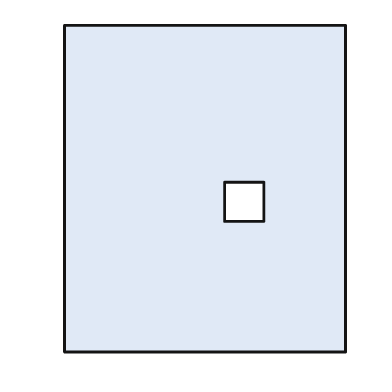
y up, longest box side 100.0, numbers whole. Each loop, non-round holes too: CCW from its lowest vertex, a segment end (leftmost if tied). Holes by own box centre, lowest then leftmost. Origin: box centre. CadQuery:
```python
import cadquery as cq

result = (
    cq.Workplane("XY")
    .moveTo(-43.0, -50.0)
    .lineTo(43.0, -50.0)
    .lineTo(43.0, 50.0)
    .lineTo(-43.0, 50.0)
    .close()
    .moveTo(6.0, -10.0)
    .lineTo(18.0, -10.0)
    .lineTo(18.0, 2.0)
    .lineTo(6.0, 2.0)
    .close()
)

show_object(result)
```